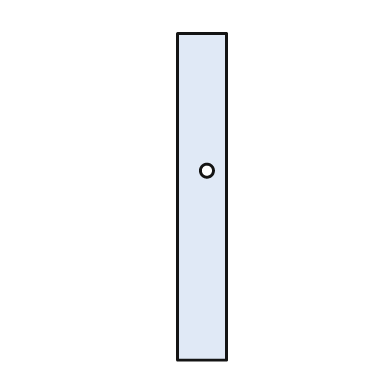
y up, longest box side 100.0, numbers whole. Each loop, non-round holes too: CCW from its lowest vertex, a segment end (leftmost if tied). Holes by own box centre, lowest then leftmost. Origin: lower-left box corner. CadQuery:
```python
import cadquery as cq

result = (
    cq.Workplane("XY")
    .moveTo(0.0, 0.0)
    .lineTo(15.0, 0.0)
    .lineTo(15.0, 100.0)
    .lineTo(0.0, 100.0)
    .close()
    .moveTo(9.0, 58.0)
    .circle(2.0)
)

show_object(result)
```